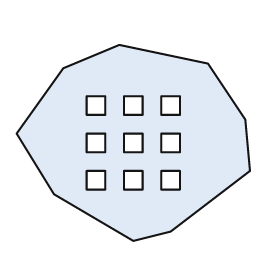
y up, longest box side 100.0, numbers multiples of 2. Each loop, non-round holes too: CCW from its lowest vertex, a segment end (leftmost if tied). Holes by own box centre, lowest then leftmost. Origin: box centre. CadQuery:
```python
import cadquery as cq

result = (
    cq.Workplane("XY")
    .moveTo(0.0, -42.0)
    .lineTo(16.0, -38.0)
    .lineTo(50.0, -12.0)
    .lineTo(48.0, 10.0)
    .lineTo(32.0, 34.0)
    .lineTo(-6.0, 42.0)
    .lineTo(-30.0, 32.0)
    .lineTo(-50.0, 4.0)
    .lineTo(-34.0, -22.0)
    .close()
    .moveTo(-20.0, -20.0)
    .lineTo(-12.0, -20.0)
    .lineTo(-12.0, -12.0)
    .lineTo(-20.0, -12.0)
    .close()
    .moveTo(-4.0, -20.0)
    .lineTo(4.0, -20.0)
    .lineTo(4.0, -12.0)
    .lineTo(-4.0, -12.0)
    .close()
    .moveTo(12.0, -20.0)
    .lineTo(20.0, -20.0)
    .lineTo(20.0, -12.0)
    .lineTo(12.0, -12.0)
    .close()
    .moveTo(-20.0, -4.0)
    .lineTo(-12.0, -4.0)
    .lineTo(-12.0, 4.0)
    .lineTo(-20.0, 4.0)
    .close()
    .moveTo(-4.0, -4.0)
    .lineTo(4.0, -4.0)
    .lineTo(4.0, 4.0)
    .lineTo(-4.0, 4.0)
    .close()
    .moveTo(12.0, -4.0)
    .lineTo(20.0, -4.0)
    .lineTo(20.0, 4.0)
    .lineTo(12.0, 4.0)
    .close()
    .moveTo(-20.0, 12.0)
    .lineTo(-12.0, 12.0)
    .lineTo(-12.0, 20.0)
    .lineTo(-20.0, 20.0)
    .close()
    .moveTo(-4.0, 12.0)
    .lineTo(4.0, 12.0)
    .lineTo(4.0, 20.0)
    .lineTo(-4.0, 20.0)
    .close()
    .moveTo(12.0, 12.0)
    .lineTo(20.0, 12.0)
    .lineTo(20.0, 20.0)
    .lineTo(12.0, 20.0)
    .close()
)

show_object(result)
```